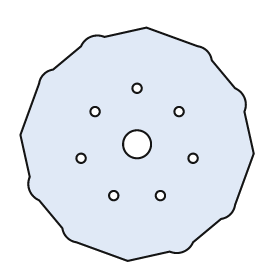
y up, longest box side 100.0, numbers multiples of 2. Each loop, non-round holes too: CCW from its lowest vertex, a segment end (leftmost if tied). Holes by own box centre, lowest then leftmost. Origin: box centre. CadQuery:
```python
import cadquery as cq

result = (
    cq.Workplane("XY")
    .moveTo(-4.0, -50.0)
    .lineTo(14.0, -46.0)
    .threePointArc((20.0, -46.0), (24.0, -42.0))
    .lineTo(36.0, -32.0)
    .threePointArc((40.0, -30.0), (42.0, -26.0))
    .lineTo(50.0, -4.0)
    .lineTo(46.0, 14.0)
    .threePointArc((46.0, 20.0), (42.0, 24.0))
    .lineTo(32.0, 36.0)
    .threePointArc((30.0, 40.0), (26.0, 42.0))
    .lineTo(4.0, 50.0)
    .lineTo(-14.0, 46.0)
    .threePointArc((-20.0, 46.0), (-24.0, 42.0))
    .lineTo(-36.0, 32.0)
    .threePointArc((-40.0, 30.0), (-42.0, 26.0))
    .lineTo(-50.0, 4.0)
    .lineTo(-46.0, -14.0)
    .threePointArc((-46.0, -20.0), (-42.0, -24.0))
    .lineTo(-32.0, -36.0)
    .threePointArc((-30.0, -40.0), (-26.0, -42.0))
    .close()
    .moveTo(-10.0, -22.0)
    .circle(2.0)
    .moveTo(10.0, -22.0)
    .circle(2.0)
    .moveTo(-24.0, -6.0)
    .circle(2.0)
    .moveTo(24.0, -6.0)
    .circle(2.0)
    .moveTo(0.0, 0.0)
    .circle(6.0)
    .moveTo(-18.0, 14.0)
    .circle(2.0)
    .moveTo(18.0, 14.0)
    .circle(2.0)
    .moveTo(0.0, 24.0)
    .circle(2.0)
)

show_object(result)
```